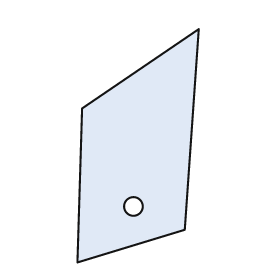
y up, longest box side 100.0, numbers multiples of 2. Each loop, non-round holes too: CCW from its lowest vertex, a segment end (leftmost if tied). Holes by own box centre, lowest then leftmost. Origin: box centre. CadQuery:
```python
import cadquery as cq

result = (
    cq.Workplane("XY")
    .moveTo(-26.0, -50.0)
    .lineTo(20.0, -36.0)
    .lineTo(26.0, 50.0)
    .lineTo(-24.0, 16.0)
    .close()
    .moveTo(-2.0, -26.0)
    .circle(4.0)
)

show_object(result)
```